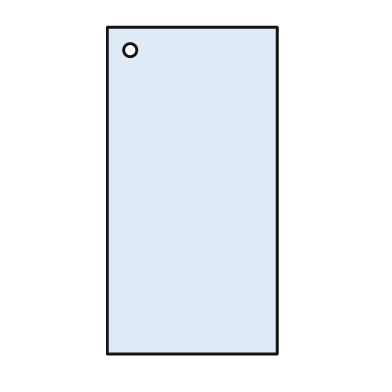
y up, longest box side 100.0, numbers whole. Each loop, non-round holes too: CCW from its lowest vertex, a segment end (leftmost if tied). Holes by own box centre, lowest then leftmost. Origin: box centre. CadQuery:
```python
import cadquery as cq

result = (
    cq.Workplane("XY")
    .moveTo(-26.0, -50.0)
    .lineTo(26.0, -50.0)
    .lineTo(26.0, 50.0)
    .lineTo(-26.0, 50.0)
    .close()
    .moveTo(-19.0, 43.0)
    .circle(2.0)
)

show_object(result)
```